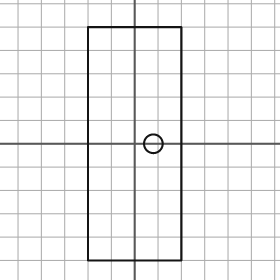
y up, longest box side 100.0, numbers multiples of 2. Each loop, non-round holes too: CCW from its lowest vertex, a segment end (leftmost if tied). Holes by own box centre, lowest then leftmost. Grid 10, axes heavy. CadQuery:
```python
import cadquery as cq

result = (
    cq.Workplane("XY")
    .moveTo(-20.0, -50.0)
    .lineTo(20.0, -50.0)
    .lineTo(20.0, 50.0)
    .lineTo(-20.0, 50.0)
    .close()
    .moveTo(8.0, 0.0)
    .circle(4.0)
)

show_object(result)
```